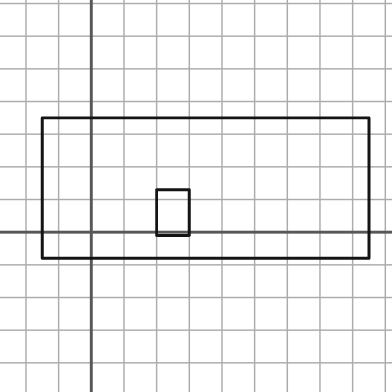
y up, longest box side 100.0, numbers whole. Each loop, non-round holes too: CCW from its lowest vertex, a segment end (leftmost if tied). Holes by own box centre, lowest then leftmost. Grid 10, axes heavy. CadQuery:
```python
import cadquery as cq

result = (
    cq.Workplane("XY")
    .moveTo(-15.0, -8.0)
    .lineTo(85.0, -8.0)
    .lineTo(85.0, 35.0)
    .lineTo(-15.0, 35.0)
    .close()
    .moveTo(20.0, -1.0)
    .lineTo(30.0, -1.0)
    .lineTo(30.0, 13.0)
    .lineTo(20.0, 13.0)
    .close()
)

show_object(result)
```